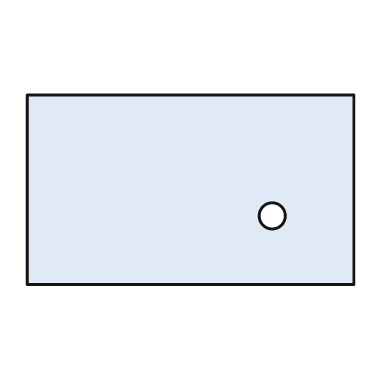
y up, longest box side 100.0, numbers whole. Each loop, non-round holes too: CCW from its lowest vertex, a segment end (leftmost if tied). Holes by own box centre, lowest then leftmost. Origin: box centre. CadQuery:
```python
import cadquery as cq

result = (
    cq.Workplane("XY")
    .moveTo(-50.0, -29.0)
    .lineTo(50.0, -29.0)
    .lineTo(50.0, 29.0)
    .lineTo(-50.0, 29.0)
    .close()
    .moveTo(25.0, -8.0)
    .circle(4.0)
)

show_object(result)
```